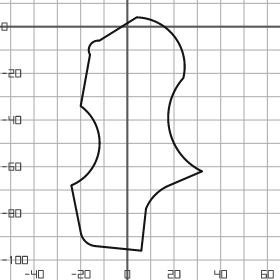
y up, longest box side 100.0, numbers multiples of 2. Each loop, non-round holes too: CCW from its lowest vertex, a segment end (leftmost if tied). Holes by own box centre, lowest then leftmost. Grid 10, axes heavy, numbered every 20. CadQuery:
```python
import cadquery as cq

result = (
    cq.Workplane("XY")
    .moveTo(6.0, -96.0)
    .lineTo(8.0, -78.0)
    .threePointArc((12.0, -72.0), (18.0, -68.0))
    .lineTo(32.0, -62.0)
    .threePointArc((18.0, -44.0), (24.0, -22.0))
    .threePointArc((20.0, -4.0), (4.0, 4.0))
    .lineTo(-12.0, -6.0)
    .threePointArc((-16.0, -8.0), (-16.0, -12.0))
    .lineTo(-20.0, -34.0)
    .threePointArc((-12.0, -52.0), (-24.0, -68.0))
    .lineTo(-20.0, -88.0)
    .threePointArc((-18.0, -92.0), (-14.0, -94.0))
    .close()
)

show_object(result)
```